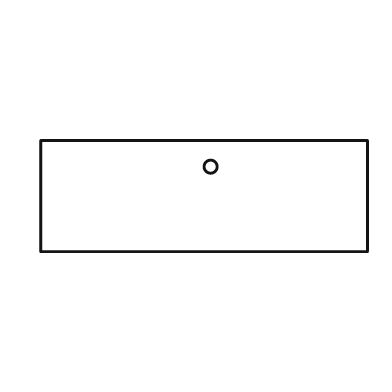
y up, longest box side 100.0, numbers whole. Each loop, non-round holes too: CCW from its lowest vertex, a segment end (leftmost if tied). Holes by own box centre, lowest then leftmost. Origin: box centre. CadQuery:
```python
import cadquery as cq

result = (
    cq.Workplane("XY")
    .moveTo(-50.0, -17.0)
    .lineTo(50.0, -17.0)
    .lineTo(50.0, 17.0)
    .lineTo(-50.0, 17.0)
    .close()
    .moveTo(2.0, 9.0)
    .circle(2.0)
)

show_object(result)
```